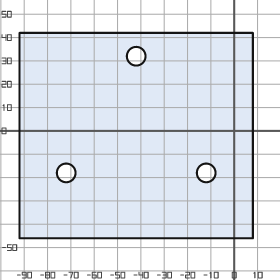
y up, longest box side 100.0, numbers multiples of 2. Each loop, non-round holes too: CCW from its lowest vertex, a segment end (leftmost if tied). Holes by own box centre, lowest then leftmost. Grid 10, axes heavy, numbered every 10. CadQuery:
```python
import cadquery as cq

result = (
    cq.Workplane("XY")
    .moveTo(-92.0, -46.0)
    .lineTo(8.0, -46.0)
    .lineTo(8.0, 42.0)
    .lineTo(-92.0, 42.0)
    .close()
    .moveTo(-72.0, -18.0)
    .circle(4.0)
    .moveTo(-12.0, -18.0)
    .circle(4.0)
    .moveTo(-42.0, 32.0)
    .circle(4.0)
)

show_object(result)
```